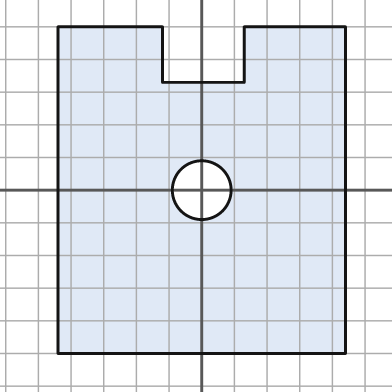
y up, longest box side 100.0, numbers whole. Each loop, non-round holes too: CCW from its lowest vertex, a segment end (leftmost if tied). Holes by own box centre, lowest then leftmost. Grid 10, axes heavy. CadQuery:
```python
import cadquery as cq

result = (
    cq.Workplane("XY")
    .moveTo(-44.0, -50.0)
    .lineTo(44.0, -50.0)
    .lineTo(44.0, 50.0)
    .lineTo(13.0, 50.0)
    .lineTo(13.0, 33.0)
    .lineTo(-12.0, 33.0)
    .lineTo(-12.0, 50.0)
    .lineTo(-44.0, 50.0)
    .close()
    .moveTo(0.0, 0.0)
    .circle(9.0)
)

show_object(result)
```